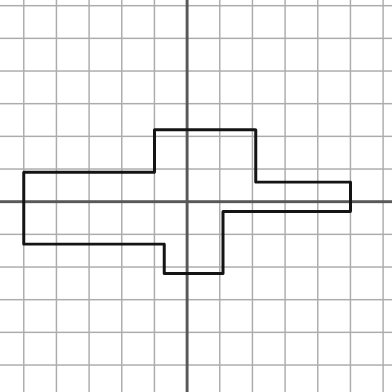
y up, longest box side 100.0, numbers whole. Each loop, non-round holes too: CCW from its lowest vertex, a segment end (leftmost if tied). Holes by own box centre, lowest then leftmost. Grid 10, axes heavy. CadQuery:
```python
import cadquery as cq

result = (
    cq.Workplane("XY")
    .moveTo(-7.0, -22.0)
    .lineTo(11.0, -22.0)
    .lineTo(11.0, -3.0)
    .lineTo(50.0, -3.0)
    .lineTo(50.0, 6.0)
    .lineTo(21.0, 6.0)
    .lineTo(21.0, 22.0)
    .lineTo(-10.0, 22.0)
    .lineTo(-10.0, 9.0)
    .lineTo(-50.0, 9.0)
    .lineTo(-50.0, -13.0)
    .lineTo(-7.0, -13.0)
    .close()
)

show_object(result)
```